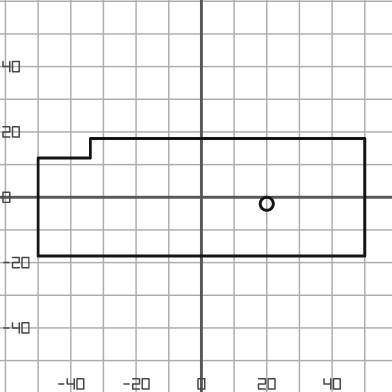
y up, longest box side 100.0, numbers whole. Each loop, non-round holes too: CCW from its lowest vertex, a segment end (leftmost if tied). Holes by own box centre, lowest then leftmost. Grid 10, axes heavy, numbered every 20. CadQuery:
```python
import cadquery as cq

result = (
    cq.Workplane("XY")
    .moveTo(-50.0, -18.0)
    .lineTo(50.0, -18.0)
    .lineTo(50.0, 18.0)
    .lineTo(-34.0, 18.0)
    .lineTo(-34.0, 12.0)
    .lineTo(-50.0, 12.0)
    .close()
    .moveTo(20.0, -2.0)
    .circle(2.0)
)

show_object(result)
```